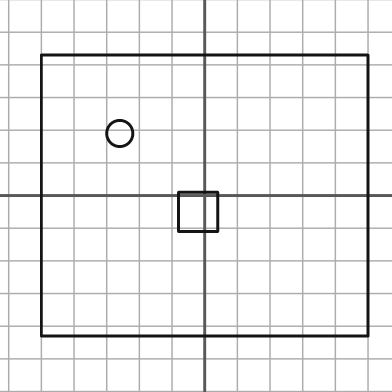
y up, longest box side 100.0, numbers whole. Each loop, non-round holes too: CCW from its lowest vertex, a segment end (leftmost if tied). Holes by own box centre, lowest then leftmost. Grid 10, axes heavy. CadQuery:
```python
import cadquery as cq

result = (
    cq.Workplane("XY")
    .moveTo(-50.0, -43.0)
    .lineTo(50.0, -43.0)
    .lineTo(50.0, 43.0)
    .lineTo(-50.0, 43.0)
    .close()
    .moveTo(-8.0, -11.0)
    .lineTo(4.0, -11.0)
    .lineTo(4.0, 1.0)
    .lineTo(-8.0, 1.0)
    .close()
    .moveTo(-26.0, 19.0)
    .circle(4.0)
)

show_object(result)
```